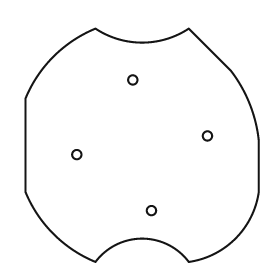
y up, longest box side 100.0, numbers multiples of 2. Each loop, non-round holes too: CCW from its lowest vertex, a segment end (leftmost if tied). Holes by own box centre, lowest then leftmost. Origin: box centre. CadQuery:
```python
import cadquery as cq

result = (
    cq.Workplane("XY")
    .moveTo(-20.0, -50.0)
    .threePointArc((0.0, -40.0), (20.0, -50.0))
    .threePointArc((40.0, -40.0), (50.0, -20.0))
    .lineTo(50.0, 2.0)
    .threePointArc((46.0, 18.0), (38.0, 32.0))
    .lineTo(20.0, 50.0)
    .threePointArc((0.0, 44.0), (-20.0, 50.0))
    .threePointArc((-38.0, 38.0), (-50.0, 20.0))
    .lineTo(-50.0, -20.0)
    .threePointArc((-38.0, -38.0), (-20.0, -50.0))
    .close()
    .moveTo(4.0, -28.0)
    .circle(2.0)
    .moveTo(-28.0, -4.0)
    .circle(2.0)
    .moveTo(28.0, 4.0)
    .circle(2.0)
    .moveTo(-4.0, 28.0)
    .circle(2.0)
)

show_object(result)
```